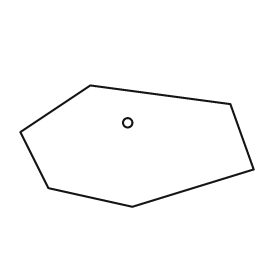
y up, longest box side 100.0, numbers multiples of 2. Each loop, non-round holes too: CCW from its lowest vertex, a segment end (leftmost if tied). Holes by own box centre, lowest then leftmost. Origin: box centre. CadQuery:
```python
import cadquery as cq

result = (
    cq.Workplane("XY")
    .moveTo(-2.0, -26.0)
    .lineTo(50.0, -10.0)
    .lineTo(40.0, 18.0)
    .lineTo(-20.0, 26.0)
    .lineTo(-50.0, 6.0)
    .lineTo(-38.0, -18.0)
    .close()
    .moveTo(-4.0, 10.0)
    .circle(2.0)
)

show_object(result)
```